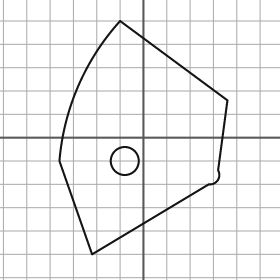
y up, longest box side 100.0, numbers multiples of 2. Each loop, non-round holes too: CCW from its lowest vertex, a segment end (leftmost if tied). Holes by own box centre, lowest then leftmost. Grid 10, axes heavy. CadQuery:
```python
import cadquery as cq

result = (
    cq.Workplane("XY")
    .moveTo(-22.0, -50.0)
    .lineTo(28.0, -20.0)
    .threePointArc((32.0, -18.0), (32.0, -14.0))
    .lineTo(36.0, 16.0)
    .lineTo(-10.0, 50.0)
    .threePointArc((-28.0, 22.0), (-36.0, -10.0))
    .close()
    .moveTo(-8.0, -10.0)
    .circle(6.0)
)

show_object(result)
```